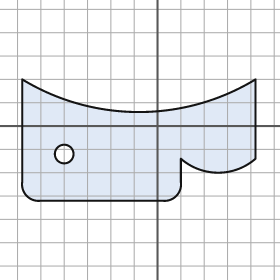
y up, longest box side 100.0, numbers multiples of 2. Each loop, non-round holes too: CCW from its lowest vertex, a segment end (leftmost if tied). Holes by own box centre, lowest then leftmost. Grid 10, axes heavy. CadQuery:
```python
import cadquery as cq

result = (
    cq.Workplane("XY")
    .moveTo(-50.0, -32.0)
    .lineTo(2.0, -32.0)
    .threePointArc((8.0, -30.0), (10.0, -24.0))
    .lineTo(10.0, -14.0)
    .threePointArc((26.0, -20.0), (42.0, -14.0))
    .lineTo(42.0, 20.0)
    .threePointArc((-8.0, 6.0), (-58.0, 20.0))
    .lineTo(-58.0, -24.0)
    .threePointArc((-56.0, -30.0), (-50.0, -32.0))
    .close()
    .moveTo(-40.0, -12.0)
    .circle(4.0)
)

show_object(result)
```